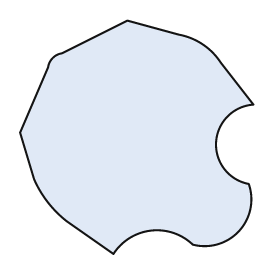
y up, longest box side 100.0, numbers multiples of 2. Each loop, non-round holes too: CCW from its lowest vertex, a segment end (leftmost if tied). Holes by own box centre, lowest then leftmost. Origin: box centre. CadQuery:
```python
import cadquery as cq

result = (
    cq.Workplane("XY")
    .moveTo(-10.0, -50.0)
    .threePointArc((6.0, -40.0), (24.0, -46.0))
    .threePointArc((44.0, -40.0), (48.0, -20.0))
    .threePointArc((34.0, -2.0), (50.0, 14.0))
    .lineTo(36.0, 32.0)
    .threePointArc((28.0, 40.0), (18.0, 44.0))
    .lineTo(-4.0, 50.0)
    .lineTo(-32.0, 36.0)
    .threePointArc((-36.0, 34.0), (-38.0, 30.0))
    .lineTo(-50.0, 2.0)
    .lineTo(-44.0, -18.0)
    .threePointArc((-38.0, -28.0), (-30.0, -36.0))
    .close()
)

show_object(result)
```